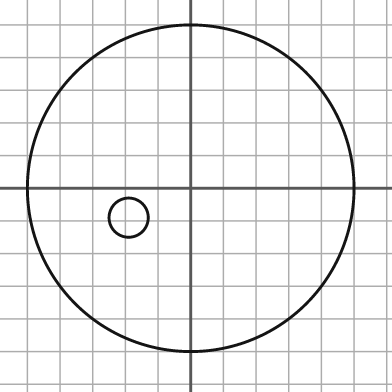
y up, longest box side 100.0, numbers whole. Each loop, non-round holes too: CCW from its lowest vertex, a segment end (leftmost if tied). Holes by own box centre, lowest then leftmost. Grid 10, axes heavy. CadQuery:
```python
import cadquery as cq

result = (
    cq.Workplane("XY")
    .moveTo(0.0, 0.0)
    .circle(50.0)
    .moveTo(-19.0, -9.0)
    .circle(6.0)
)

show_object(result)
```